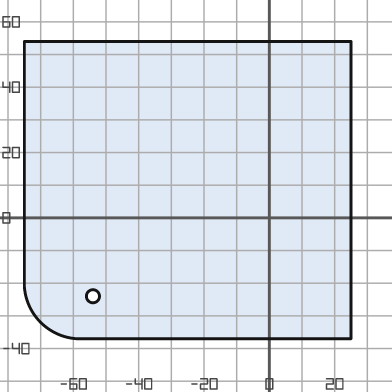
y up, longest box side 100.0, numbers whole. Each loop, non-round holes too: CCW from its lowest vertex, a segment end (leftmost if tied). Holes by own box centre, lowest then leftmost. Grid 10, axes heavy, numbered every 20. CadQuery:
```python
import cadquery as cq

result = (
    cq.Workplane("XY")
    .moveTo(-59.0, -37.0)
    .lineTo(25.0, -37.0)
    .lineTo(25.0, 54.0)
    .lineTo(-75.0, 54.0)
    .lineTo(-75.0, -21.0)
    .threePointArc((-70.0, -32.0), (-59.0, -37.0))
    .close()
    .moveTo(-54.0, -24.0)
    .circle(2.0)
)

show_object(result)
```